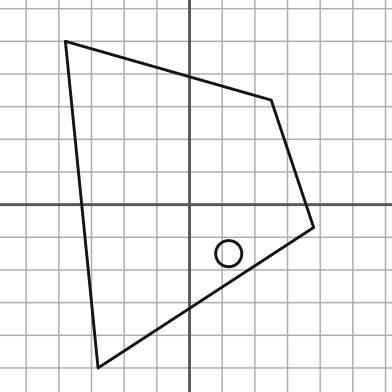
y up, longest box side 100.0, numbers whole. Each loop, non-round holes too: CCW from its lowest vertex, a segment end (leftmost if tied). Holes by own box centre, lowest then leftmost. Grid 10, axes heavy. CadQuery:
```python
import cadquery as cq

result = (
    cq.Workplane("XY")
    .moveTo(-28.0, -50.0)
    .lineTo(38.0, -7.0)
    .lineTo(25.0, 32.0)
    .lineTo(-38.0, 50.0)
    .close()
    .moveTo(12.0, -15.0)
    .circle(4.0)
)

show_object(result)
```